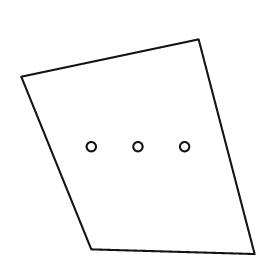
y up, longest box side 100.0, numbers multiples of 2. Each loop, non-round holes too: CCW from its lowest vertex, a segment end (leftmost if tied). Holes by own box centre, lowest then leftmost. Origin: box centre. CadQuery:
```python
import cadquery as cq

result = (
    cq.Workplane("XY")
    .moveTo(50.0, -46.0)
    .lineTo(26.0, 46.0)
    .lineTo(-50.0, 30.0)
    .lineTo(-20.0, -44.0)
    .close()
    .moveTo(-20.0, 0.0)
    .circle(2.0)
    .moveTo(0.0, 0.0)
    .circle(2.0)
    .moveTo(20.0, 0.0)
    .circle(2.0)
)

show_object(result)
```